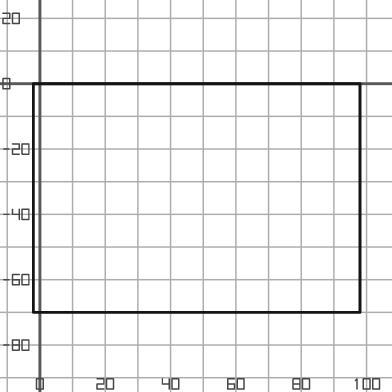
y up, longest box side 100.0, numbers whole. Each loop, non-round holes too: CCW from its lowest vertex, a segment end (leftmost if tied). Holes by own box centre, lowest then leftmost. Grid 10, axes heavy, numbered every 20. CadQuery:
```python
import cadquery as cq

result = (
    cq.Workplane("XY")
    .moveTo(-2.0, -70.0)
    .lineTo(98.0, -70.0)
    .lineTo(98.0, 0.0)
    .lineTo(-2.0, 0.0)
    .close()
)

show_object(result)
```